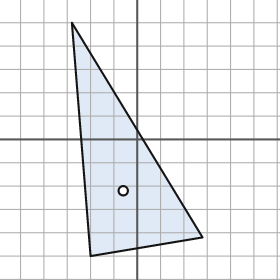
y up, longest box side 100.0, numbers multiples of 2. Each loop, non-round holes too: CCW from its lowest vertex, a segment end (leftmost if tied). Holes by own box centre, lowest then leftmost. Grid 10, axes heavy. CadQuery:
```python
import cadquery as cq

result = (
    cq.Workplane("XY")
    .moveTo(-20.0, -50.0)
    .lineTo(28.0, -42.0)
    .lineTo(-28.0, 50.0)
    .close()
    .moveTo(-6.0, -22.0)
    .circle(2.0)
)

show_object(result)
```